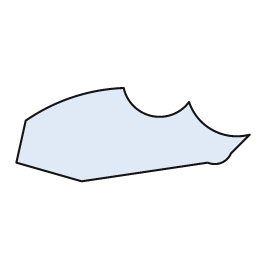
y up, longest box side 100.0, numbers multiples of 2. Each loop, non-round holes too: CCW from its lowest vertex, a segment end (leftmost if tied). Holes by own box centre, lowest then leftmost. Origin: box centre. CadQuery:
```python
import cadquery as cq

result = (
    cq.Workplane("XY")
    .moveTo(-22.0, -20.0)
    .lineTo(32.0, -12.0)
    .threePointArc((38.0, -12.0), (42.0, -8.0))
    .lineTo(50.0, 0.0)
    .threePointArc((34.0, 2.0), (24.0, 14.0))
    .threePointArc((8.0, 8.0), (-4.0, 20.0))
    .threePointArc((-26.0, 16.0), (-46.0, 6.0))
    .lineTo(-50.0, -12.0)
    .close()
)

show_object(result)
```